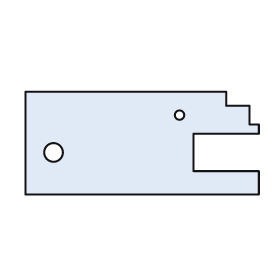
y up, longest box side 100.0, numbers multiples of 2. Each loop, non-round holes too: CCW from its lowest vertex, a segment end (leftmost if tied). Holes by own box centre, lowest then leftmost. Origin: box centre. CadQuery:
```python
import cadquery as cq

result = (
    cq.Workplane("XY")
    .moveTo(-50.0, -22.0)
    .lineTo(50.0, -22.0)
    .lineTo(50.0, -12.0)
    .lineTo(22.0, -12.0)
    .lineTo(22.0, 4.0)
    .lineTo(50.0, 4.0)
    .lineTo(50.0, 8.0)
    .lineTo(46.0, 8.0)
    .lineTo(46.0, 16.0)
    .lineTo(36.0, 16.0)
    .lineTo(36.0, 22.0)
    .lineTo(-50.0, 22.0)
    .close()
    .moveTo(-38.0, -4.0)
    .circle(4.0)
    .moveTo(16.0, 12.0)
    .circle(2.0)
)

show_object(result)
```